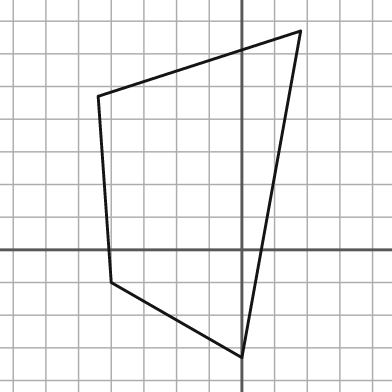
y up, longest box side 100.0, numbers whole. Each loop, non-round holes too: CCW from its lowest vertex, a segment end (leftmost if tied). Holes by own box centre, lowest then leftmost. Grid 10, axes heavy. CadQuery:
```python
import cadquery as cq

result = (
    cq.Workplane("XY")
    .moveTo(0.0, -33.0)
    .lineTo(18.0, 67.0)
    .lineTo(-44.0, 47.0)
    .lineTo(-40.0, -10.0)
    .close()
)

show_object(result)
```